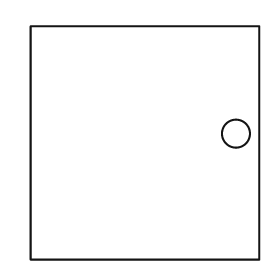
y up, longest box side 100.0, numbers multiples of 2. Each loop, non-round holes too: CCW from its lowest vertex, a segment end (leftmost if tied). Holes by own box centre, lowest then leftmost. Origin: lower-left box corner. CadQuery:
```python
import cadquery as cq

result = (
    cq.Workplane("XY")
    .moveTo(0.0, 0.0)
    .lineTo(98.0, 0.0)
    .lineTo(98.0, 100.0)
    .lineTo(0.0, 100.0)
    .close()
    .moveTo(88.0, 54.0)
    .circle(6.0)
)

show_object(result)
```